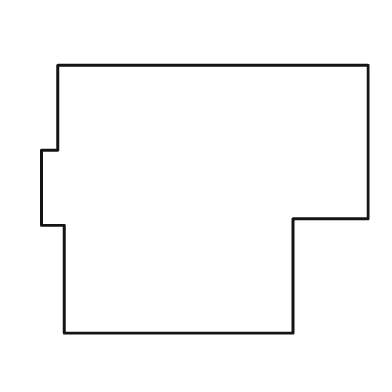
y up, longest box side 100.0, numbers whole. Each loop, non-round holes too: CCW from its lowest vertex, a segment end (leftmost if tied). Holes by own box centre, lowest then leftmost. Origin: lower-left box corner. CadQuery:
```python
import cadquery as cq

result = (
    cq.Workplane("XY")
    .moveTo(7.0, 0.0)
    .lineTo(77.0, 0.0)
    .lineTo(77.0, 35.0)
    .lineTo(100.0, 35.0)
    .lineTo(100.0, 82.0)
    .lineTo(5.0, 82.0)
    .lineTo(5.0, 56.0)
    .lineTo(0.0, 56.0)
    .lineTo(0.0, 33.0)
    .lineTo(7.0, 33.0)
    .close()
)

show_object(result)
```